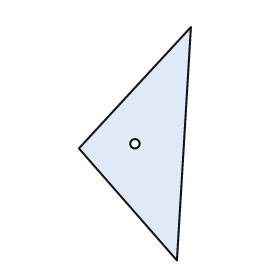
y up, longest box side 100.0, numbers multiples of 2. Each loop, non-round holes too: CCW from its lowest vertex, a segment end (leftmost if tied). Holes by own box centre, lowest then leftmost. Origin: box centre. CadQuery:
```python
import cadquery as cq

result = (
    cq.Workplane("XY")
    .moveTo(18.0, -50.0)
    .lineTo(24.0, 50.0)
    .lineTo(-24.0, -2.0)
    .close()
    .moveTo(0.0, 0.0)
    .circle(2.0)
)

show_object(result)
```